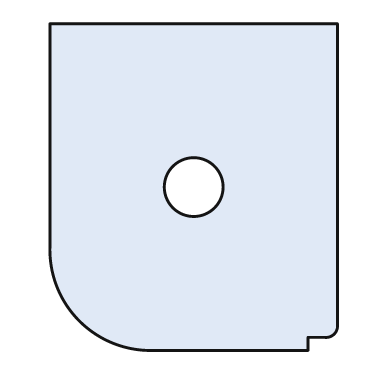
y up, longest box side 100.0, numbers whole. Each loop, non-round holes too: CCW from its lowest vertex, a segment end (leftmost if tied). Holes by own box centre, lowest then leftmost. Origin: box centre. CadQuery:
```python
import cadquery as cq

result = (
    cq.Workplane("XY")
    .moveTo(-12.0, -50.0)
    .lineTo(35.0, -50.0)
    .lineTo(35.0, -46.0)
    .lineTo(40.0, -46.0)
    .threePointArc((43.0, -45.0), (44.0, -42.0))
    .lineTo(44.0, 50.0)
    .lineTo(-44.0, 50.0)
    .lineTo(-44.0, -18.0)
    .threePointArc((-35.0, -41.0), (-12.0, -50.0))
    .close()
    .moveTo(0.0, 0.0)
    .circle(9.0)
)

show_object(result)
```